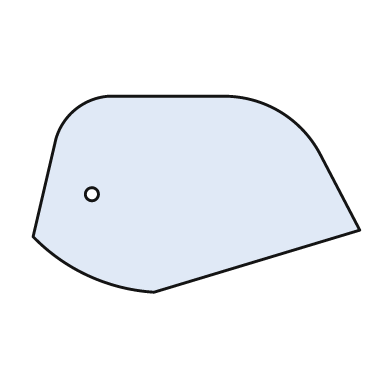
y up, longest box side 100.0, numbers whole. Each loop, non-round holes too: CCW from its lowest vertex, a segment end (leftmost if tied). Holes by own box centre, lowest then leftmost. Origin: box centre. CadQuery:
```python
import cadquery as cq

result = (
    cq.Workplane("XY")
    .moveTo(-13.0, -30.0)
    .lineTo(50.0, -11.0)
    .lineTo(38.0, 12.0)
    .threePointArc((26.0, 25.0), (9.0, 30.0))
    .lineTo(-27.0, 30.0)
    .threePointArc((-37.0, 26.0), (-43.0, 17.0))
    .lineTo(-50.0, -13.0)
    .threePointArc((-33.0, -25.0), (-13.0, -30.0))
    .close()
    .moveTo(-32.0, 0.0)
    .circle(2.0)
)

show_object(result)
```